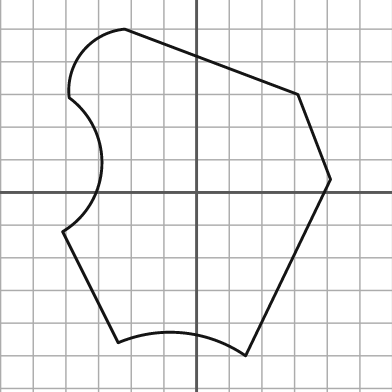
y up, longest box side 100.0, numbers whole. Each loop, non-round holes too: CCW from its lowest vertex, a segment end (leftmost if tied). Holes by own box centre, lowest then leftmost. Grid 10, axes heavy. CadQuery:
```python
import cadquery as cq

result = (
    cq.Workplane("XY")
    .moveTo(15.0, -50.0)
    .lineTo(41.0, 4.0)
    .lineTo(31.0, 30.0)
    .lineTo(-22.0, 50.0)
    .threePointArc((-35.0, 43.0), (-39.0, 29.0))
    .threePointArc((-29.0, 8.0), (-41.0, -12.0))
    .lineTo(-24.0, -46.0)
    .threePointArc((-4.0, -43.0), (15.0, -50.0))
    .close()
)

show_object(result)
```